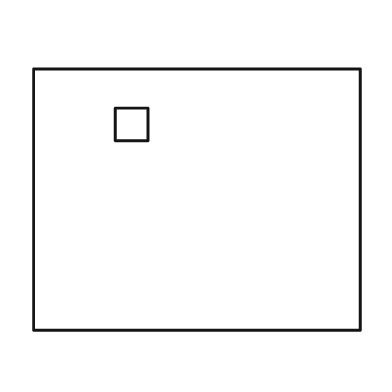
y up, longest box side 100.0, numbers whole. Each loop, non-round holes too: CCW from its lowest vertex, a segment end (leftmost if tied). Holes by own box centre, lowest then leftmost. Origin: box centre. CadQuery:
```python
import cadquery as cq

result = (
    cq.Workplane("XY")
    .moveTo(-50.0, -40.0)
    .lineTo(50.0, -40.0)
    .lineTo(50.0, 40.0)
    .lineTo(-50.0, 40.0)
    .close()
    .moveTo(-25.0, 18.0)
    .lineTo(-15.0, 18.0)
    .lineTo(-15.0, 28.0)
    .lineTo(-25.0, 28.0)
    .close()
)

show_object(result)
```